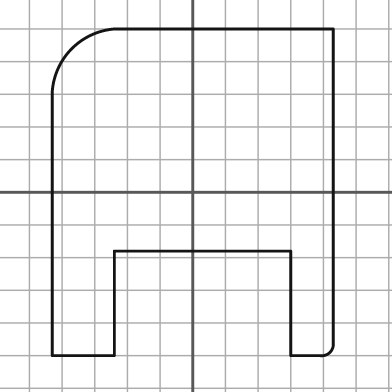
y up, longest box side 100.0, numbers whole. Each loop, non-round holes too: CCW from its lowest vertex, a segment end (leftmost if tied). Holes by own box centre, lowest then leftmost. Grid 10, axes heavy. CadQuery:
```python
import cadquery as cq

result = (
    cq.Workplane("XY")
    .moveTo(-43.0, -50.0)
    .lineTo(-24.0, -50.0)
    .lineTo(-24.0, -18.0)
    .lineTo(30.0, -18.0)
    .lineTo(30.0, -50.0)
    .lineTo(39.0, -50.0)
    .threePointArc((42.0, -49.0), (43.0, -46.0))
    .lineTo(43.0, 50.0)
    .lineTo(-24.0, 50.0)
    .threePointArc((-37.0, 44.0), (-43.0, 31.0))
    .close()
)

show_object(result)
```